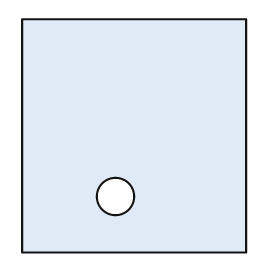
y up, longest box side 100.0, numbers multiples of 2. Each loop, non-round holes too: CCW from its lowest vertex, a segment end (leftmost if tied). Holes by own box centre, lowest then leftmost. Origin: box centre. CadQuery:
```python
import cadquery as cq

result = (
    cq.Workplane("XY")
    .moveTo(-48.0, -50.0)
    .lineTo(48.0, -50.0)
    .lineTo(48.0, 50.0)
    .lineTo(-48.0, 50.0)
    .close()
    .moveTo(-8.0, -26.0)
    .circle(8.0)
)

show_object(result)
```